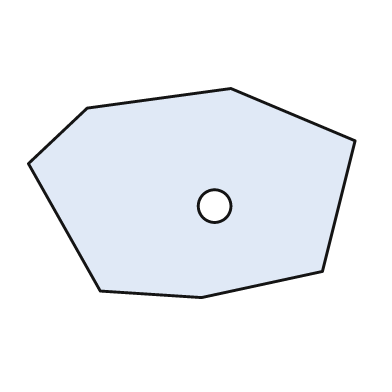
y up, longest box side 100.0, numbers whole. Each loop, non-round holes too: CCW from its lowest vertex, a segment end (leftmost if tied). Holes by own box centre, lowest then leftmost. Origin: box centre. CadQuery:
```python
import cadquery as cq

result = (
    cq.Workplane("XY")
    .moveTo(3.0, -32.0)
    .lineTo(40.0, -24.0)
    .lineTo(50.0, 16.0)
    .lineTo(12.0, 32.0)
    .lineTo(-32.0, 26.0)
    .lineTo(-50.0, 9.0)
    .lineTo(-28.0, -30.0)
    .close()
    .moveTo(7.0, -4.0)
    .circle(5.0)
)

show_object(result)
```